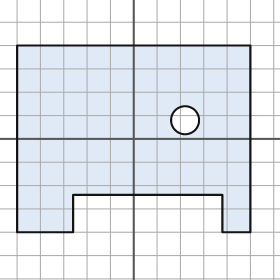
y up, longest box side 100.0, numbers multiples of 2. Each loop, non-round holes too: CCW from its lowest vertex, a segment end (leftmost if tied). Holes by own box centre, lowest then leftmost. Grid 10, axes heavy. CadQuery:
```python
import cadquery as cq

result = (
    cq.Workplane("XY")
    .moveTo(-50.0, -40.0)
    .lineTo(-26.0, -40.0)
    .lineTo(-26.0, -24.0)
    .lineTo(38.0, -24.0)
    .lineTo(38.0, -40.0)
    .lineTo(50.0, -40.0)
    .lineTo(50.0, 40.0)
    .lineTo(-50.0, 40.0)
    .close()
    .moveTo(22.0, 8.0)
    .circle(6.0)
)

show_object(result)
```